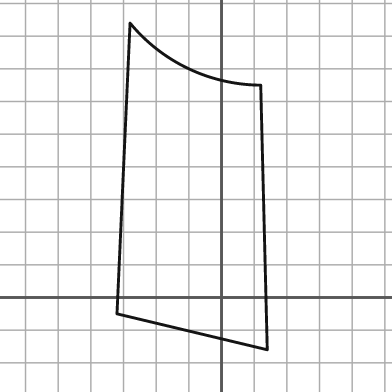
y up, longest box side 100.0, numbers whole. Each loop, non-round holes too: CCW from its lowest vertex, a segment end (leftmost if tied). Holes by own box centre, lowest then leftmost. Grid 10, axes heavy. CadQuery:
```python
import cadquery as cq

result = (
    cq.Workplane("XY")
    .moveTo(14.0, -16.0)
    .lineTo(12.0, 65.0)
    .threePointArc((-10.0, 70.0), (-28.0, 84.0))
    .lineTo(-32.0, -5.0)
    .close()
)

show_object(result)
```